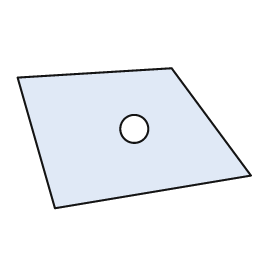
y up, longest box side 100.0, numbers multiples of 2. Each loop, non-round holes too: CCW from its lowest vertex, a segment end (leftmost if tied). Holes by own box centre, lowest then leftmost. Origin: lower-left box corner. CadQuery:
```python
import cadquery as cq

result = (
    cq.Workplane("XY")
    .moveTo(16.0, 0.0)
    .lineTo(100.0, 14.0)
    .lineTo(66.0, 60.0)
    .lineTo(0.0, 56.0)
    .close()
    .moveTo(50.0, 34.0)
    .circle(6.0)
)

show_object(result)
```